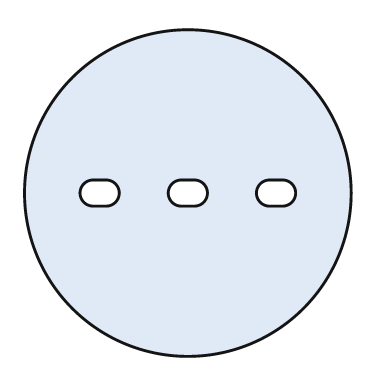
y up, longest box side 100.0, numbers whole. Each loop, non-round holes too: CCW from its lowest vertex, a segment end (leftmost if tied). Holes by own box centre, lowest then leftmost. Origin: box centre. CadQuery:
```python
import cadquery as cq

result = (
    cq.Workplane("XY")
    .moveTo(0.0, 0.0)
    .circle(50.0)
    .moveTo(-29.0, -4.0)
    .lineTo(-25.0, -4.0)
    .threePointArc((-21.0, 0.0), (-25.0, 4.0))
    .lineTo(-29.0, 4.0)
    .threePointArc((-33.0, 0.0), (-29.0, -4.0))
    .close()
    .moveTo(-2.0, -4.0)
    .lineTo(2.0, -4.0)
    .threePointArc((6.0, 0.0), (2.0, 4.0))
    .lineTo(-2.0, 4.0)
    .threePointArc((-6.0, 0.0), (-2.0, -4.0))
    .close()
    .moveTo(25.0, -4.0)
    .lineTo(29.0, -4.0)
    .threePointArc((33.0, 0.0), (29.0, 4.0))
    .lineTo(25.0, 4.0)
    .threePointArc((21.0, 0.0), (25.0, -4.0))
    .close()
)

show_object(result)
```